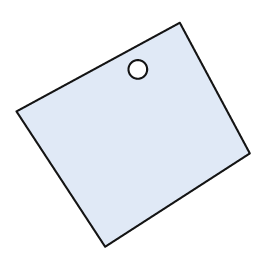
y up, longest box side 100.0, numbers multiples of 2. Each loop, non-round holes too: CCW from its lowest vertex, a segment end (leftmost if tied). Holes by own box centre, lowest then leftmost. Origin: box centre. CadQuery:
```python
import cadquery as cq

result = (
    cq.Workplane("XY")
    .moveTo(-12.0, -48.0)
    .lineTo(50.0, -8.0)
    .lineTo(20.0, 48.0)
    .lineTo(-50.0, 10.0)
    .close()
    .moveTo(2.0, 28.0)
    .circle(4.0)
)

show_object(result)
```